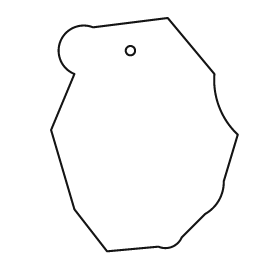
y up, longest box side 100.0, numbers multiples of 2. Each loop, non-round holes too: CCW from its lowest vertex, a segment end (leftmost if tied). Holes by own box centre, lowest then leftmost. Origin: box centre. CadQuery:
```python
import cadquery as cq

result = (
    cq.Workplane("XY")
    .moveTo(-16.0, -50.0)
    .lineTo(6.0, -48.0)
    .threePointArc((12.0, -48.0), (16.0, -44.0))
    .lineTo(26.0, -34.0)
    .threePointArc((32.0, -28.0), (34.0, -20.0))
    .lineTo(40.0, 0.0)
    .threePointArc((32.0, 12.0), (30.0, 26.0))
    .lineTo(10.0, 50.0)
    .lineTo(-22.0, 46.0)
    .threePointArc((-36.0, 40.0), (-30.0, 26.0))
    .lineTo(-40.0, 2.0)
    .lineTo(-30.0, -32.0)
    .close()
    .moveTo(-6.0, 36.0)
    .circle(2.0)
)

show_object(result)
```